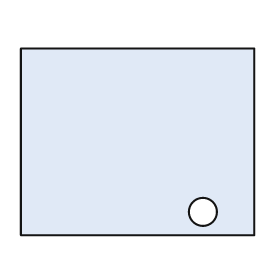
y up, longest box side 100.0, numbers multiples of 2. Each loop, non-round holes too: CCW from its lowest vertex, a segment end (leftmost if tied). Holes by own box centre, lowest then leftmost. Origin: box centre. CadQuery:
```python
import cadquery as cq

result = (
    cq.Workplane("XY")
    .moveTo(-50.0, -40.0)
    .lineTo(50.0, -40.0)
    .lineTo(50.0, 40.0)
    .lineTo(-50.0, 40.0)
    .close()
    .moveTo(28.0, -30.0)
    .circle(6.0)
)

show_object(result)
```